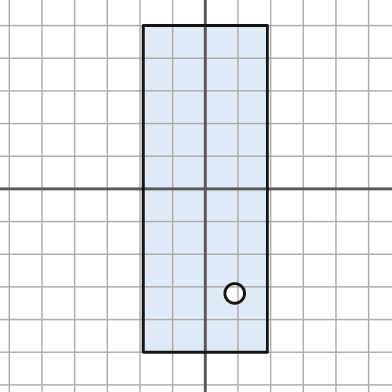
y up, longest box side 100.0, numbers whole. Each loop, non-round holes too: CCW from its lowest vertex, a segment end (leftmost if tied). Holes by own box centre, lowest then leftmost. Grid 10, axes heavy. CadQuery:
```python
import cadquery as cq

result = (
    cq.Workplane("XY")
    .moveTo(-19.0, -50.0)
    .lineTo(19.0, -50.0)
    .lineTo(19.0, 50.0)
    .lineTo(-19.0, 50.0)
    .close()
    .moveTo(9.0, -32.0)
    .circle(3.0)
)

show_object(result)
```